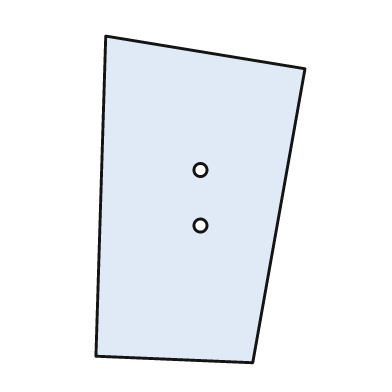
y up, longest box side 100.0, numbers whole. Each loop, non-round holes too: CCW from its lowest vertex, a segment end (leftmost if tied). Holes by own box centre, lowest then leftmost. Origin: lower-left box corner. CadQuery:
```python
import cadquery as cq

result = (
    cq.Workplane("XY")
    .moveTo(48.0, 0.0)
    .lineTo(64.0, 90.0)
    .lineTo(3.0, 100.0)
    .lineTo(0.0, 2.0)
    .close()
    .moveTo(32.0, 42.0)
    .circle(2.0)
    .moveTo(32.0, 59.0)
    .circle(2.0)
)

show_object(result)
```